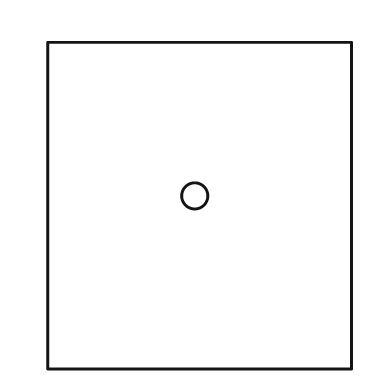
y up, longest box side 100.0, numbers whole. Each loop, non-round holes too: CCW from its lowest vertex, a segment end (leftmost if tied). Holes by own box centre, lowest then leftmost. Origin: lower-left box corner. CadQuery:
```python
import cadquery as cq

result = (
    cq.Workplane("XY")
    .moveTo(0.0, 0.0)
    .lineTo(93.0, 0.0)
    .lineTo(93.0, 100.0)
    .lineTo(0.0, 100.0)
    .close()
    .moveTo(45.0, 53.0)
    .circle(4.0)
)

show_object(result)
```